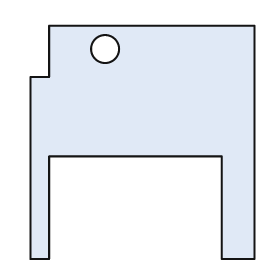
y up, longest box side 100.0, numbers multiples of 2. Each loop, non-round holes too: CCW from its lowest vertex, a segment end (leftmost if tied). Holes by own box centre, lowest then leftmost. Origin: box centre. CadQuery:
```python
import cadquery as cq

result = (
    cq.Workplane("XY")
    .moveTo(-48.0, -50.0)
    .lineTo(-40.0, -50.0)
    .lineTo(-40.0, -6.0)
    .lineTo(34.0, -6.0)
    .lineTo(34.0, -50.0)
    .lineTo(48.0, -50.0)
    .lineTo(48.0, 50.0)
    .lineTo(-40.0, 50.0)
    .lineTo(-40.0, 28.0)
    .lineTo(-48.0, 28.0)
    .close()
    .moveTo(-16.0, 40.0)
    .circle(6.0)
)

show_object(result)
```